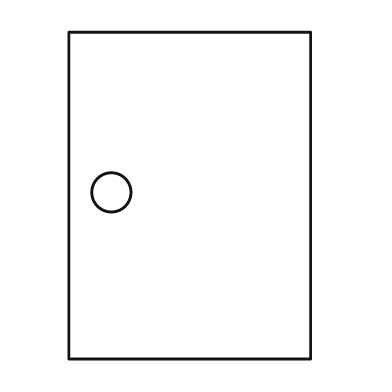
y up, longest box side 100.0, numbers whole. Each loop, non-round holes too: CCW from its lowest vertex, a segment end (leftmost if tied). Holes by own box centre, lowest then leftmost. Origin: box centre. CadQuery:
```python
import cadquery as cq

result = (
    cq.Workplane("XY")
    .moveTo(-37.0, -50.0)
    .lineTo(37.0, -50.0)
    .lineTo(37.0, 50.0)
    .lineTo(-37.0, 50.0)
    .close()
    .moveTo(-24.0, 1.0)
    .circle(6.0)
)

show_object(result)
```